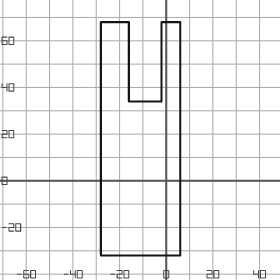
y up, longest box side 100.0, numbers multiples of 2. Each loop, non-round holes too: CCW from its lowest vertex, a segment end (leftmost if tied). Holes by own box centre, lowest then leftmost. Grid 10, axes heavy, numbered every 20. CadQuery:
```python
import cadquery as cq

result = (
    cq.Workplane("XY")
    .moveTo(-28.0, -32.0)
    .lineTo(6.0, -32.0)
    .lineTo(6.0, 68.0)
    .lineTo(-2.0, 68.0)
    .lineTo(-2.0, 34.0)
    .lineTo(-16.0, 34.0)
    .lineTo(-16.0, 68.0)
    .lineTo(-28.0, 68.0)
    .close()
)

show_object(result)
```